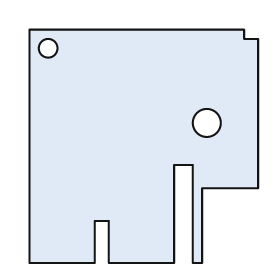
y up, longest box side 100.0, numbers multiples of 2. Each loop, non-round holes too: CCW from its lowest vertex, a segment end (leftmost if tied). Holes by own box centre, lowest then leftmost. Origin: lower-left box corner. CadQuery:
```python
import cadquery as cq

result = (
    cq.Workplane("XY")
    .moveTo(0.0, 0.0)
    .lineTo(28.0, 0.0)
    .lineTo(28.0, 18.0)
    .lineTo(34.0, 18.0)
    .lineTo(34.0, 0.0)
    .lineTo(62.0, 0.0)
    .lineTo(62.0, 42.0)
    .lineTo(70.0, 42.0)
    .lineTo(70.0, 0.0)
    .lineTo(74.0, 0.0)
    .lineTo(74.0, 32.0)
    .lineTo(98.0, 32.0)
    .lineTo(98.0, 96.0)
    .lineTo(92.0, 96.0)
    .lineTo(92.0, 100.0)
    .lineTo(0.0, 100.0)
    .close()
    .moveTo(76.0, 60.0)
    .circle(6.0)
    .moveTo(8.0, 92.0)
    .circle(4.0)
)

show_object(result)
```